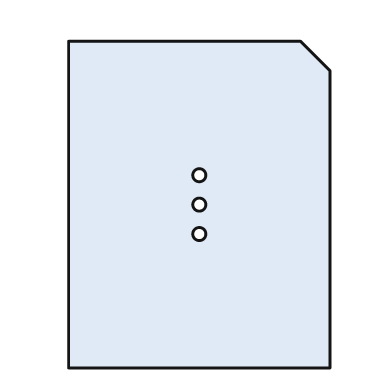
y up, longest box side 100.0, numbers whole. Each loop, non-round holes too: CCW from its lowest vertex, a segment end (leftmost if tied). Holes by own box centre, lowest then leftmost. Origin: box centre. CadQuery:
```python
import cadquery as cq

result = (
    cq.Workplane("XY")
    .moveTo(-40.0, -50.0)
    .lineTo(40.0, -50.0)
    .lineTo(40.0, 41.0)
    .lineTo(31.0, 50.0)
    .lineTo(-40.0, 50.0)
    .close()
    .moveTo(0.0, -9.0)
    .circle(2.0)
    .moveTo(0.0, 0.0)
    .circle(2.0)
    .moveTo(0.0, 9.0)
    .circle(2.0)
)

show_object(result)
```